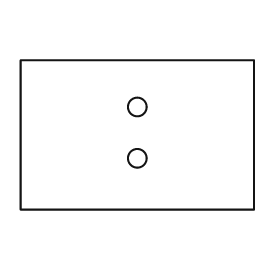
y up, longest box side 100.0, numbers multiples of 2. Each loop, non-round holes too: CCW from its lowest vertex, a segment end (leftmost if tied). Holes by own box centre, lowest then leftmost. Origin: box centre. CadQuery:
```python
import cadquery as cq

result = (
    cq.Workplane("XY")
    .moveTo(-50.0, -32.0)
    .lineTo(50.0, -32.0)
    .lineTo(50.0, 32.0)
    .lineTo(-50.0, 32.0)
    .close()
    .moveTo(0.0, -10.0)
    .circle(4.0)
    .moveTo(0.0, 12.0)
    .circle(4.0)
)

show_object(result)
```